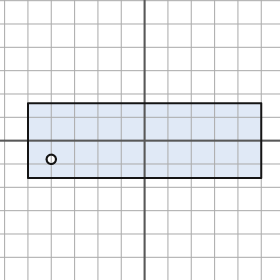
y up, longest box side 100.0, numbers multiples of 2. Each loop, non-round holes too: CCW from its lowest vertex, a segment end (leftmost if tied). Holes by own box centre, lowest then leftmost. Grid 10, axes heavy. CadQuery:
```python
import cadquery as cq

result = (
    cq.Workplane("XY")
    .moveTo(-50.0, -16.0)
    .lineTo(50.0, -16.0)
    .lineTo(50.0, 16.0)
    .lineTo(-50.0, 16.0)
    .close()
    .moveTo(-40.0, -8.0)
    .circle(2.0)
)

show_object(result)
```